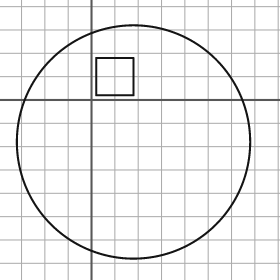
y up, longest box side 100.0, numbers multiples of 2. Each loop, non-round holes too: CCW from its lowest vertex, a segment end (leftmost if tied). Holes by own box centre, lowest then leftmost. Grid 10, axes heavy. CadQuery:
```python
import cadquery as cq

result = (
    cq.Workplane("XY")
    .moveTo(18.0, -18.0)
    .circle(50.0)
    .moveTo(2.0, 2.0)
    .lineTo(18.0, 2.0)
    .lineTo(18.0, 18.0)
    .lineTo(2.0, 18.0)
    .close()
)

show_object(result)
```